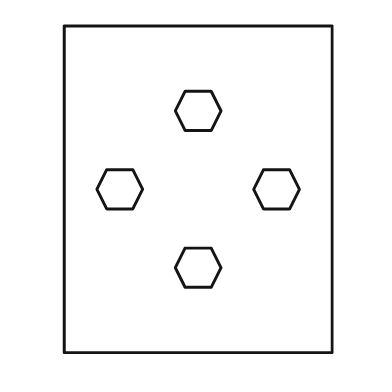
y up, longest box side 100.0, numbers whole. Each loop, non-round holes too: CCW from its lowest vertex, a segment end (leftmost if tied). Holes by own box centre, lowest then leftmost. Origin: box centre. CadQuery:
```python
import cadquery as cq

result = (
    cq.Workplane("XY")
    .moveTo(-41.0, -50.0)
    .lineTo(41.0, -50.0)
    .lineTo(41.0, 50.0)
    .lineTo(-41.0, 50.0)
    .close()
    .moveTo(-4.0, -30.0)
    .lineTo(4.0, -30.0)
    .lineTo(7.0, -24.0)
    .lineTo(4.0, -18.0)
    .lineTo(-4.0, -18.0)
    .lineTo(-7.0, -24.0)
    .close()
    .moveTo(-28.0, -6.0)
    .lineTo(-20.0, -6.0)
    .lineTo(-17.0, 0.0)
    .lineTo(-20.0, 6.0)
    .lineTo(-28.0, 6.0)
    .lineTo(-31.0, 0.0)
    .close()
    .moveTo(20.0, -6.0)
    .lineTo(28.0, -6.0)
    .lineTo(31.0, 0.0)
    .lineTo(28.0, 6.0)
    .lineTo(20.0, 6.0)
    .lineTo(17.0, 0.0)
    .close()
    .moveTo(-4.0, 18.0)
    .lineTo(4.0, 18.0)
    .lineTo(7.0, 24.0)
    .lineTo(4.0, 30.0)
    .lineTo(-4.0, 30.0)
    .lineTo(-7.0, 24.0)
    .close()
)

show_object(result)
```